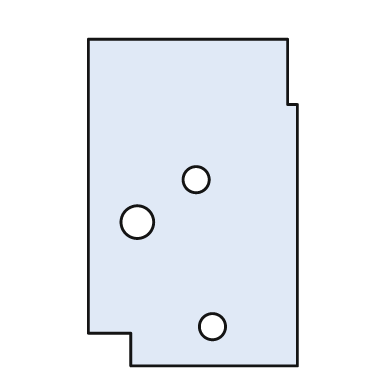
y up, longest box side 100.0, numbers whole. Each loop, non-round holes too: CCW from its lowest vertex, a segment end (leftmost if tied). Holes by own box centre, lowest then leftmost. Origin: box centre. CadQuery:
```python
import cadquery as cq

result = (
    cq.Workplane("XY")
    .moveTo(-19.0, -50.0)
    .lineTo(32.0, -50.0)
    .lineTo(32.0, 30.0)
    .lineTo(29.0, 30.0)
    .lineTo(29.0, 50.0)
    .lineTo(-32.0, 50.0)
    .lineTo(-32.0, -40.0)
    .lineTo(-19.0, -40.0)
    .close()
    .moveTo(6.0, -38.0)
    .circle(4.0)
    .moveTo(-17.0, -6.0)
    .circle(5.0)
    .moveTo(1.0, 7.0)
    .circle(4.0)
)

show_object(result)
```